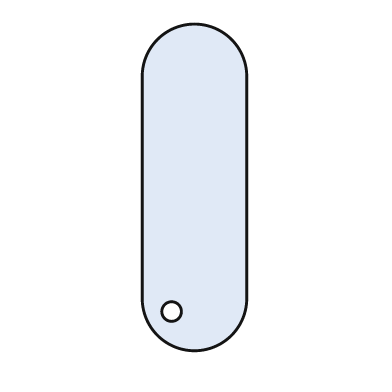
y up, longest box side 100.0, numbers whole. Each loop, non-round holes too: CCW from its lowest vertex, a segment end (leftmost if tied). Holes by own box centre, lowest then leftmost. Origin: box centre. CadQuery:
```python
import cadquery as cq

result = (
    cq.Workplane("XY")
    .moveTo(-16.0, -34.0)
    .threePointArc((0.0, -50.0), (16.0, -34.0))
    .lineTo(16.0, 34.0)
    .threePointArc((0.0, 50.0), (-16.0, 34.0))
    .close()
    .moveTo(-7.0, -38.0)
    .circle(3.0)
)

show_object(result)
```